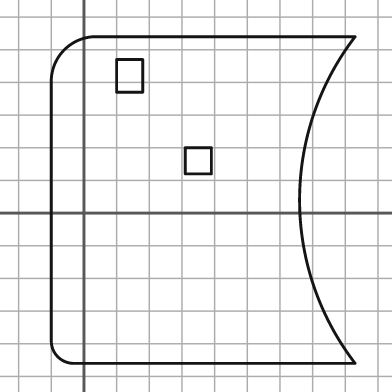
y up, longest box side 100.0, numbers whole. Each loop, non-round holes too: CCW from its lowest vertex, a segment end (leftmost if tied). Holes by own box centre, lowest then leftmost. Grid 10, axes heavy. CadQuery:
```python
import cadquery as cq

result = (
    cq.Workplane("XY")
    .moveTo(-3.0, -46.0)
    .lineTo(83.0, -46.0)
    .threePointArc((66.0, 4.0), (83.0, 54.0))
    .lineTo(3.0, 54.0)
    .threePointArc((-6.0, 50.0), (-10.0, 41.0))
    .lineTo(-10.0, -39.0)
    .threePointArc((-8.0, -44.0), (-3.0, -46.0))
    .close()
    .moveTo(31.0, 12.0)
    .lineTo(39.0, 12.0)
    .lineTo(39.0, 20.0)
    .lineTo(31.0, 20.0)
    .close()
    .moveTo(10.0, 37.0)
    .lineTo(18.0, 37.0)
    .lineTo(18.0, 47.0)
    .lineTo(10.0, 47.0)
    .close()
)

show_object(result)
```